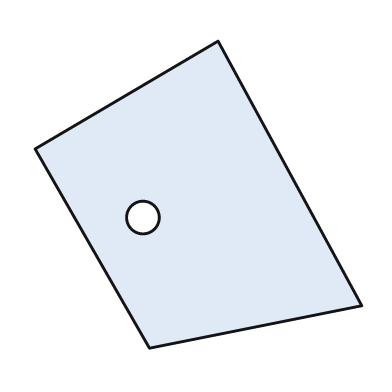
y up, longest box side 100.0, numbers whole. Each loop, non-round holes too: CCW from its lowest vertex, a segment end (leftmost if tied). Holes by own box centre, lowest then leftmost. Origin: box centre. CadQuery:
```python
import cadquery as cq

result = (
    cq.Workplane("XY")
    .moveTo(-15.0, -47.0)
    .lineTo(50.0, -34.0)
    .lineTo(6.0, 47.0)
    .lineTo(-50.0, 14.0)
    .close()
    .moveTo(-17.0, -7.0)
    .circle(5.0)
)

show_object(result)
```